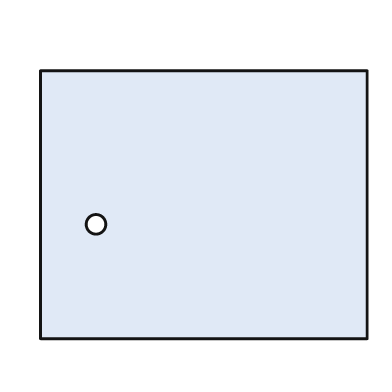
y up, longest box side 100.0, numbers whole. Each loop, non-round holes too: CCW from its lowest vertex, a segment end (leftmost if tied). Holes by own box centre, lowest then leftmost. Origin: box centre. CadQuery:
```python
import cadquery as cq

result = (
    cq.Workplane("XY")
    .moveTo(-50.0, -41.0)
    .lineTo(50.0, -41.0)
    .lineTo(50.0, 41.0)
    .lineTo(-50.0, 41.0)
    .close()
    .moveTo(-33.0, -6.0)
    .circle(3.0)
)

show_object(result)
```